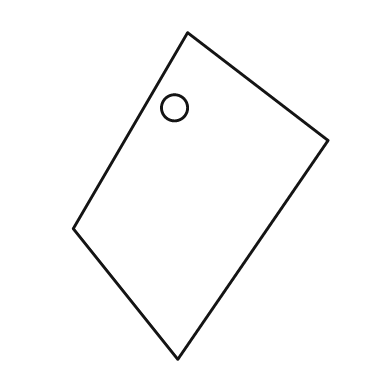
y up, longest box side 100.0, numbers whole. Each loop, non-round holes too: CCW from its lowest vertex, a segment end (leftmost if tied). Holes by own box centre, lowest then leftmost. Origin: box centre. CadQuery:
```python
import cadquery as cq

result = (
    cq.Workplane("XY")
    .moveTo(-7.0, -50.0)
    .lineTo(39.0, 17.0)
    .lineTo(-4.0, 50.0)
    .lineTo(-39.0, -10.0)
    .close()
    .moveTo(-8.0, 27.0)
    .circle(4.0)
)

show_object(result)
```